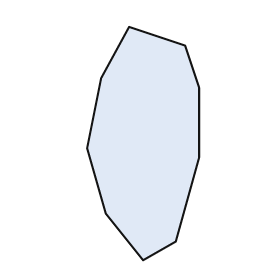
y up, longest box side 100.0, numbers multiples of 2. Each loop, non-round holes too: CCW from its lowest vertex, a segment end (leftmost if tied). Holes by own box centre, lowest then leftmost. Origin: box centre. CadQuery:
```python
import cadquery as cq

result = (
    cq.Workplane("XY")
    .moveTo(0.0, -50.0)
    .lineTo(14.0, -42.0)
    .lineTo(24.0, -6.0)
    .lineTo(24.0, 24.0)
    .lineTo(18.0, 42.0)
    .lineTo(-6.0, 50.0)
    .lineTo(-18.0, 28.0)
    .lineTo(-24.0, -2.0)
    .lineTo(-16.0, -30.0)
    .close()
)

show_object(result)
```